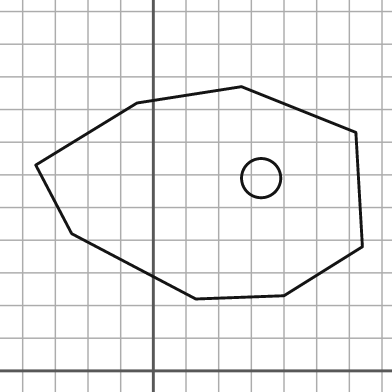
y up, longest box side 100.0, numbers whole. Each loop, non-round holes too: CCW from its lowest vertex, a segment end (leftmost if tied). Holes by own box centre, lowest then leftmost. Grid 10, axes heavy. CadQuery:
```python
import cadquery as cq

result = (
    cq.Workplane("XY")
    .moveTo(13.0, 22.0)
    .lineTo(40.0, 23.0)
    .lineTo(64.0, 38.0)
    .lineTo(62.0, 73.0)
    .lineTo(27.0, 87.0)
    .lineTo(-5.0, 82.0)
    .lineTo(-36.0, 63.0)
    .lineTo(-25.0, 42.0)
    .close()
    .moveTo(33.0, 59.0)
    .circle(6.0)
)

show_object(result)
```